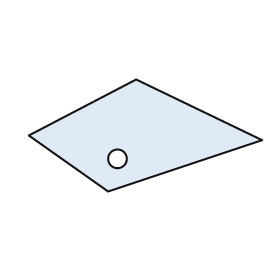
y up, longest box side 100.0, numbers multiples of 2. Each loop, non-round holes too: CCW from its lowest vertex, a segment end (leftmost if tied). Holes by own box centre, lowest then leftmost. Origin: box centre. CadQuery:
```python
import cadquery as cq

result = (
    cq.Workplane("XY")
    .moveTo(-16.0, -24.0)
    .lineTo(50.0, -2.0)
    .lineTo(-4.0, 24.0)
    .lineTo(-50.0, 0.0)
    .close()
    .moveTo(-12.0, -10.0)
    .circle(4.0)
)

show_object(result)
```